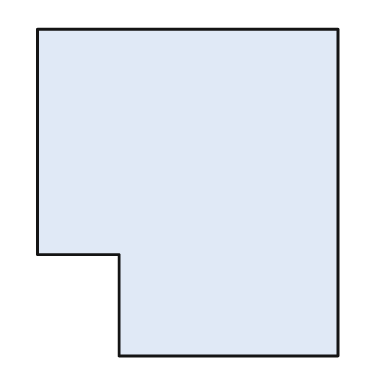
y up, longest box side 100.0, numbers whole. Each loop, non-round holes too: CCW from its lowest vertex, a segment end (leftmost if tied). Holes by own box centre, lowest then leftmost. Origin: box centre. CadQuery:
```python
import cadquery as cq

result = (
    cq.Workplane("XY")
    .moveTo(-21.0, -50.0)
    .lineTo(46.0, -50.0)
    .lineTo(46.0, 50.0)
    .lineTo(-46.0, 50.0)
    .lineTo(-46.0, -19.0)
    .lineTo(-21.0, -19.0)
    .close()
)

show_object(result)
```